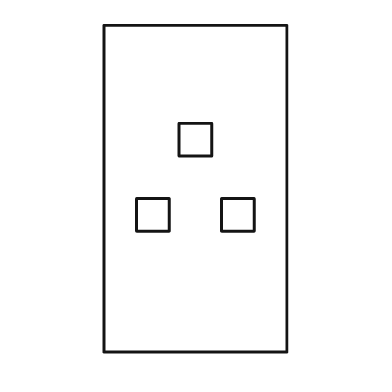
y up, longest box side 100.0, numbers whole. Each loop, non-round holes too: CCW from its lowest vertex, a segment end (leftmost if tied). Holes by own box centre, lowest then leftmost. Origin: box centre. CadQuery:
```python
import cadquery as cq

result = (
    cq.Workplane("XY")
    .moveTo(-28.0, -50.0)
    .lineTo(28.0, -50.0)
    .lineTo(28.0, 50.0)
    .lineTo(-28.0, 50.0)
    .close()
    .moveTo(-18.0, -13.0)
    .lineTo(-8.0, -13.0)
    .lineTo(-8.0, -3.0)
    .lineTo(-18.0, -3.0)
    .close()
    .moveTo(8.0, -13.0)
    .lineTo(18.0, -13.0)
    .lineTo(18.0, -3.0)
    .lineTo(8.0, -3.0)
    .close()
    .moveTo(-5.0, 10.0)
    .lineTo(5.0, 10.0)
    .lineTo(5.0, 20.0)
    .lineTo(-5.0, 20.0)
    .close()
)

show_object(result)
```